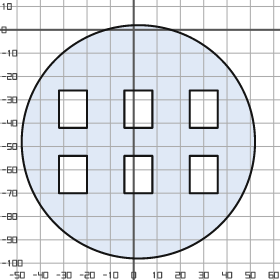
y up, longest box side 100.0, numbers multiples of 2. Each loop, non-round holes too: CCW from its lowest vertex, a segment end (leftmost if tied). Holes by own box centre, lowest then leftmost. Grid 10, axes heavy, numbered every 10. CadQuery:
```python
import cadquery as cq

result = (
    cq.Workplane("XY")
    .moveTo(2.0, -48.0)
    .circle(50.0)
    .moveTo(-32.0, -70.0)
    .lineTo(-20.0, -70.0)
    .lineTo(-20.0, -54.0)
    .lineTo(-32.0, -54.0)
    .close()
    .moveTo(-4.0, -70.0)
    .lineTo(8.0, -70.0)
    .lineTo(8.0, -54.0)
    .lineTo(-4.0, -54.0)
    .close()
    .moveTo(24.0, -70.0)
    .lineTo(36.0, -70.0)
    .lineTo(36.0, -54.0)
    .lineTo(24.0, -54.0)
    .close()
    .moveTo(-32.0, -42.0)
    .lineTo(-20.0, -42.0)
    .lineTo(-20.0, -26.0)
    .lineTo(-32.0, -26.0)
    .close()
    .moveTo(-4.0, -42.0)
    .lineTo(8.0, -42.0)
    .lineTo(8.0, -26.0)
    .lineTo(-4.0, -26.0)
    .close()
    .moveTo(24.0, -42.0)
    .lineTo(36.0, -42.0)
    .lineTo(36.0, -26.0)
    .lineTo(24.0, -26.0)
    .close()
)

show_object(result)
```